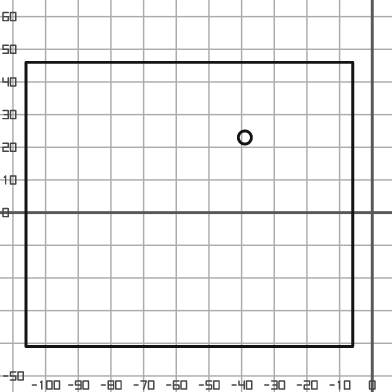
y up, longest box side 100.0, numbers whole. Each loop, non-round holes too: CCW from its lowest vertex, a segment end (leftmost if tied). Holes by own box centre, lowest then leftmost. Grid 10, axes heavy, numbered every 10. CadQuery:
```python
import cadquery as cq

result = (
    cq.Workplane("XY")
    .moveTo(-106.0, -41.0)
    .lineTo(-6.0, -41.0)
    .lineTo(-6.0, 46.0)
    .lineTo(-106.0, 46.0)
    .close()
    .moveTo(-39.0, 23.0)
    .circle(2.0)
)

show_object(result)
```